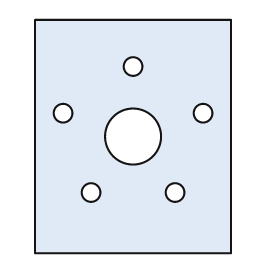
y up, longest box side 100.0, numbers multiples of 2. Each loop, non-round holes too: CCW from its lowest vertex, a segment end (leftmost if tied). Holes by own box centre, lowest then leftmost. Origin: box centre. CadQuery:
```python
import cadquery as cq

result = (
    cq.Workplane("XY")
    .moveTo(-42.0, -50.0)
    .lineTo(42.0, -50.0)
    .lineTo(42.0, 50.0)
    .lineTo(-42.0, 50.0)
    .close()
    .moveTo(-18.0, -24.0)
    .circle(4.0)
    .moveTo(18.0, -24.0)
    .circle(4.0)
    .moveTo(0.0, 0.0)
    .circle(12.0)
    .moveTo(-30.0, 10.0)
    .circle(4.0)
    .moveTo(30.0, 10.0)
    .circle(4.0)
    .moveTo(0.0, 30.0)
    .circle(4.0)
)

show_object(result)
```